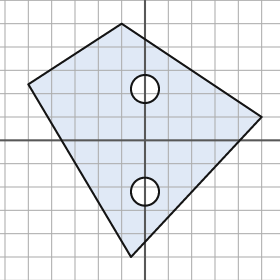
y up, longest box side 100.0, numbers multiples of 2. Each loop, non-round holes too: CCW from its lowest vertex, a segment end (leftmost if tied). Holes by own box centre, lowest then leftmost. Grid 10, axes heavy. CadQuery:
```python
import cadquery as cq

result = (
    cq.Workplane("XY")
    .moveTo(-6.0, -50.0)
    .lineTo(50.0, 10.0)
    .lineTo(-10.0, 50.0)
    .lineTo(-50.0, 24.0)
    .close()
    .moveTo(0.0, -22.0)
    .circle(6.0)
    .moveTo(0.0, 22.0)
    .circle(6.0)
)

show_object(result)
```